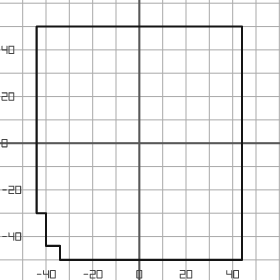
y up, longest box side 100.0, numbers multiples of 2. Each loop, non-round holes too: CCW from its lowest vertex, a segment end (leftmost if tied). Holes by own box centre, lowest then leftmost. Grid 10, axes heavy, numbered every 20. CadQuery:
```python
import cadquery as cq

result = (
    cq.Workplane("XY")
    .moveTo(-34.0, -50.0)
    .lineTo(44.0, -50.0)
    .lineTo(44.0, 50.0)
    .lineTo(-44.0, 50.0)
    .lineTo(-44.0, -30.0)
    .lineTo(-40.0, -30.0)
    .lineTo(-40.0, -44.0)
    .lineTo(-34.0, -44.0)
    .close()
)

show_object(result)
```